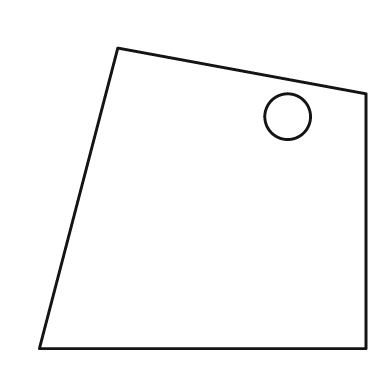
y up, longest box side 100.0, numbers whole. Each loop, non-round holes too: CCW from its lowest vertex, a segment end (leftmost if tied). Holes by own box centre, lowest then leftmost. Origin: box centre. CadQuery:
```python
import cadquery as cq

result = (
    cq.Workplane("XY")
    .moveTo(-50.0, -46.0)
    .lineTo(50.0, -46.0)
    .lineTo(50.0, 32.0)
    .lineTo(-26.0, 46.0)
    .close()
    .moveTo(26.0, 25.0)
    .circle(7.0)
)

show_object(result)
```